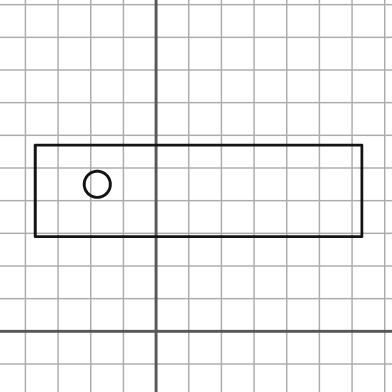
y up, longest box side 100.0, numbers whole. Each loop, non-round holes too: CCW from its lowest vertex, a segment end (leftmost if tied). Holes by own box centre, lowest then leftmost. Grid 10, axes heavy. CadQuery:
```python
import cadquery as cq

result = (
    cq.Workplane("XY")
    .moveTo(-37.0, 29.0)
    .lineTo(63.0, 29.0)
    .lineTo(63.0, 57.0)
    .lineTo(-37.0, 57.0)
    .close()
    .moveTo(-18.0, 45.0)
    .circle(4.0)
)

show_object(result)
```